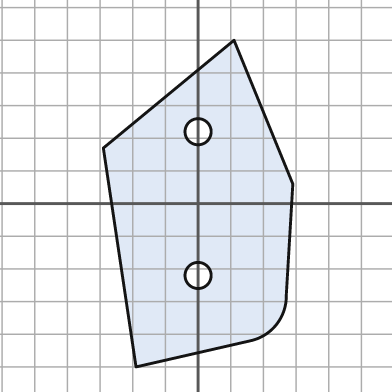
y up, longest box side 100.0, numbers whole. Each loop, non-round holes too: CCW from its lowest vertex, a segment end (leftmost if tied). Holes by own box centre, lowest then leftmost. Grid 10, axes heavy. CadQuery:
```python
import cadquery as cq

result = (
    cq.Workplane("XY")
    .moveTo(-19.0, -50.0)
    .lineTo(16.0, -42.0)
    .threePointArc((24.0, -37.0), (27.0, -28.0))
    .lineTo(29.0, 6.0)
    .lineTo(11.0, 50.0)
    .lineTo(-29.0, 17.0)
    .close()
    .moveTo(0.0, -22.0)
    .circle(4.0)
    .moveTo(0.0, 22.0)
    .circle(4.0)
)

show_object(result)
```